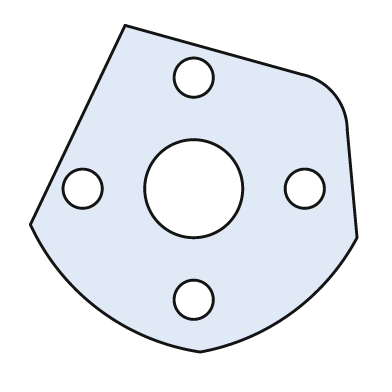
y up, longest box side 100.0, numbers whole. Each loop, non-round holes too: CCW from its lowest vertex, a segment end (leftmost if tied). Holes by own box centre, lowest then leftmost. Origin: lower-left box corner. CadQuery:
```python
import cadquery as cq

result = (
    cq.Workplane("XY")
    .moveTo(52.0, 0.0)
    .threePointArc((80.0, 12.0), (100.0, 35.0))
    .lineTo(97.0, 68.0)
    .threePointArc((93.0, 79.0), (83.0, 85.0))
    .lineTo(29.0, 100.0)
    .lineTo(0.0, 39.0)
    .threePointArc((21.0, 13.0), (52.0, 0.0))
    .close()
    .moveTo(50.0, 16.0)
    .circle(6.0)
    .moveTo(16.0, 50.0)
    .circle(6.0)
    .moveTo(50.0, 50.0)
    .circle(15.0)
    .moveTo(84.0, 50.0)
    .circle(6.0)
    .moveTo(50.0, 84.0)
    .circle(6.0)
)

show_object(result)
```